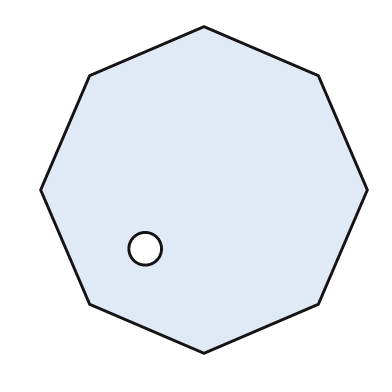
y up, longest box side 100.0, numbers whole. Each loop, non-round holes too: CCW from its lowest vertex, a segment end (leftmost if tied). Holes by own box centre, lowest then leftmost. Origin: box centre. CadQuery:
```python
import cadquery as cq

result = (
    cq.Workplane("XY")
    .moveTo(0.0, -50.0)
    .lineTo(35.0, -35.0)
    .lineTo(50.0, 0.0)
    .lineTo(35.0, 35.0)
    .lineTo(0.0, 50.0)
    .lineTo(-35.0, 35.0)
    .lineTo(-50.0, 0.0)
    .lineTo(-35.0, -35.0)
    .close()
    .moveTo(-18.0, -18.0)
    .circle(5.0)
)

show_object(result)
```